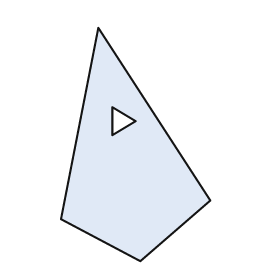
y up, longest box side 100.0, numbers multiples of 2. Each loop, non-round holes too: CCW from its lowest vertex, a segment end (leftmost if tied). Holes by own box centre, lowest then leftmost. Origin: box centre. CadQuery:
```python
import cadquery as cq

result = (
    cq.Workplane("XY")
    .moveTo(2.0, -50.0)
    .lineTo(32.0, -24.0)
    .lineTo(-16.0, 50.0)
    .lineTo(-32.0, -32.0)
    .close()
    .moveTo(-10.0, 4.0)
    .lineTo(0.0, 10.0)
    .lineTo(-10.0, 16.0)
    .close()
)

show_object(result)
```